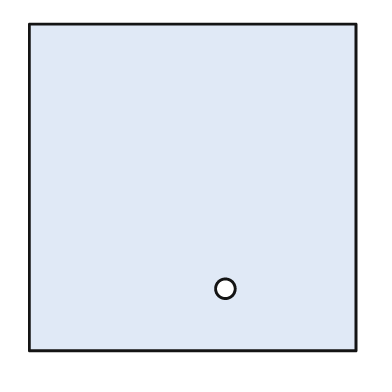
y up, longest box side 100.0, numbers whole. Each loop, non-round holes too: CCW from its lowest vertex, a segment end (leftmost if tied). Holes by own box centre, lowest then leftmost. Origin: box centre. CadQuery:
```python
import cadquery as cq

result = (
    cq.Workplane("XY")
    .moveTo(-50.0, -50.0)
    .lineTo(50.0, -50.0)
    .lineTo(50.0, 50.0)
    .lineTo(-50.0, 50.0)
    .close()
    .moveTo(10.0, -31.0)
    .circle(3.0)
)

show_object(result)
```